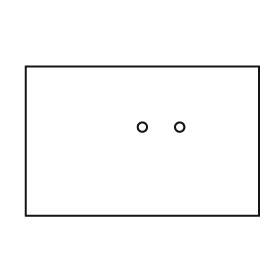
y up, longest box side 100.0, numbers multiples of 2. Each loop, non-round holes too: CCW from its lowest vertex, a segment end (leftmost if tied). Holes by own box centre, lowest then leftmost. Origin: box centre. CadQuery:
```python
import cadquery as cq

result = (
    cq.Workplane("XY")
    .moveTo(-50.0, -32.0)
    .lineTo(50.0, -32.0)
    .lineTo(50.0, 32.0)
    .lineTo(-50.0, 32.0)
    .close()
    .moveTo(0.0, 6.0)
    .circle(2.0)
    .moveTo(16.0, 6.0)
    .circle(2.0)
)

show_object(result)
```